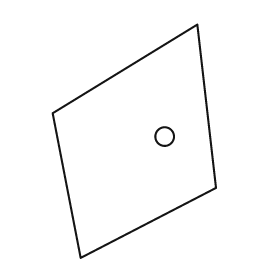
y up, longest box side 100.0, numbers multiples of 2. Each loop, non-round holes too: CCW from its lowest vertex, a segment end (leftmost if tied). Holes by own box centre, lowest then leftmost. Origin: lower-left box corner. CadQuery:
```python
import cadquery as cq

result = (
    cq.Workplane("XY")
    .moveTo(12.0, 0.0)
    .lineTo(70.0, 30.0)
    .lineTo(62.0, 100.0)
    .lineTo(0.0, 62.0)
    .close()
    .moveTo(48.0, 52.0)
    .circle(4.0)
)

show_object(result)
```